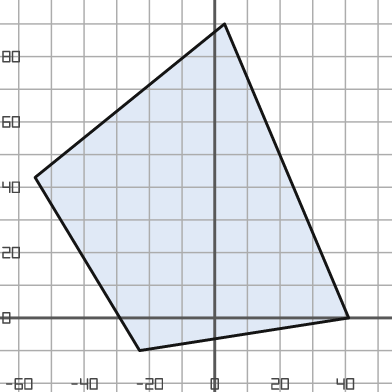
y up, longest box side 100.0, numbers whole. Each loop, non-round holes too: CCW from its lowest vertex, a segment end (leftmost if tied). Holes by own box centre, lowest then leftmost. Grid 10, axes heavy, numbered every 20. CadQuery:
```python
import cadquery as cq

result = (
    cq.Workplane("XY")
    .moveTo(-23.0, -10.0)
    .lineTo(41.0, 0.0)
    .lineTo(3.0, 90.0)
    .lineTo(-55.0, 43.0)
    .close()
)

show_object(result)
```